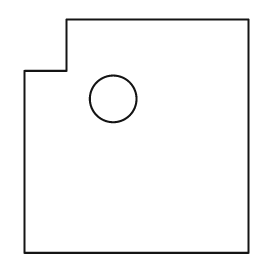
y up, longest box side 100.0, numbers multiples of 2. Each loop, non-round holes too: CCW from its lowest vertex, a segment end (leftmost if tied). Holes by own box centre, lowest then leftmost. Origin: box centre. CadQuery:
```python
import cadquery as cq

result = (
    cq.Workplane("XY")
    .moveTo(-48.0, -50.0)
    .lineTo(48.0, -50.0)
    .lineTo(48.0, 50.0)
    .lineTo(-30.0, 50.0)
    .lineTo(-30.0, 28.0)
    .lineTo(-48.0, 28.0)
    .close()
    .moveTo(-10.0, 16.0)
    .circle(10.0)
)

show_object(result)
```